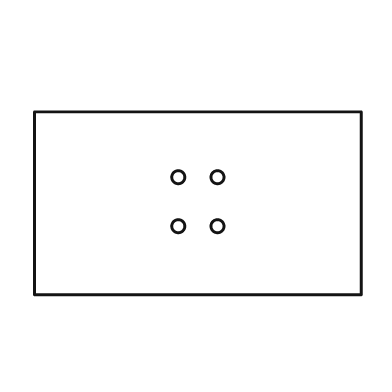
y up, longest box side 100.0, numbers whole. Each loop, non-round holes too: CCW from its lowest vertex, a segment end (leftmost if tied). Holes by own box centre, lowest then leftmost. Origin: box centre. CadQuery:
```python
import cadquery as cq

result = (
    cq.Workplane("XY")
    .moveTo(-50.0, -28.0)
    .lineTo(50.0, -28.0)
    .lineTo(50.0, 28.0)
    .lineTo(-50.0, 28.0)
    .close()
    .moveTo(-6.0, -7.0)
    .circle(2.0)
    .moveTo(6.0, -7.0)
    .circle(2.0)
    .moveTo(-6.0, 8.0)
    .circle(2.0)
    .moveTo(6.0, 8.0)
    .circle(2.0)
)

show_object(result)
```